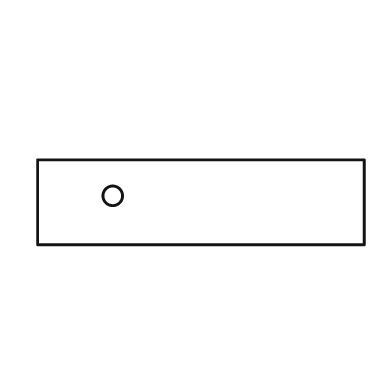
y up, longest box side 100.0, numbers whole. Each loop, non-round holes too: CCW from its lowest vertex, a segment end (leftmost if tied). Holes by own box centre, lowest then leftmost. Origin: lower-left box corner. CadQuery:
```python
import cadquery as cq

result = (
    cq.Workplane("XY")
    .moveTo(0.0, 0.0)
    .lineTo(100.0, 0.0)
    .lineTo(100.0, 26.0)
    .lineTo(0.0, 26.0)
    .close()
    .moveTo(23.0, 15.0)
    .circle(3.0)
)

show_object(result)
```